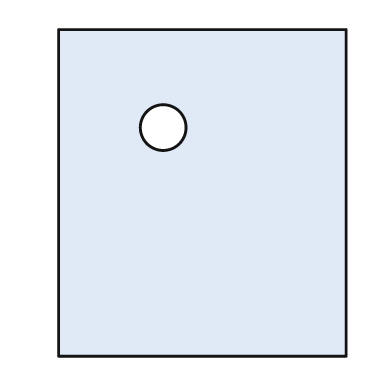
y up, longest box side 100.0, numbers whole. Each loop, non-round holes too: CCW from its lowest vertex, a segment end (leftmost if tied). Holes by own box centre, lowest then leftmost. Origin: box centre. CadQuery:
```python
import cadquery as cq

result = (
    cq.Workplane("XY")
    .moveTo(-44.0, -50.0)
    .lineTo(44.0, -50.0)
    .lineTo(44.0, 50.0)
    .lineTo(-44.0, 50.0)
    .close()
    .moveTo(-12.0, 20.0)
    .circle(7.0)
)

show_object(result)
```